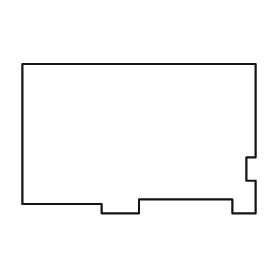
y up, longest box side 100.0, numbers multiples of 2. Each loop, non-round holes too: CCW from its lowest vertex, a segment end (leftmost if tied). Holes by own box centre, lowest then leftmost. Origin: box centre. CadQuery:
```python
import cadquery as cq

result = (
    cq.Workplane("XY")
    .moveTo(-16.0, -32.0)
    .lineTo(0.0, -32.0)
    .lineTo(0.0, -26.0)
    .lineTo(40.0, -26.0)
    .lineTo(40.0, -32.0)
    .lineTo(50.0, -32.0)
    .lineTo(50.0, -18.0)
    .lineTo(46.0, -18.0)
    .lineTo(46.0, -8.0)
    .lineTo(50.0, -8.0)
    .lineTo(50.0, 32.0)
    .lineTo(-50.0, 32.0)
    .lineTo(-50.0, -28.0)
    .lineTo(-16.0, -28.0)
    .close()
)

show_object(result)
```